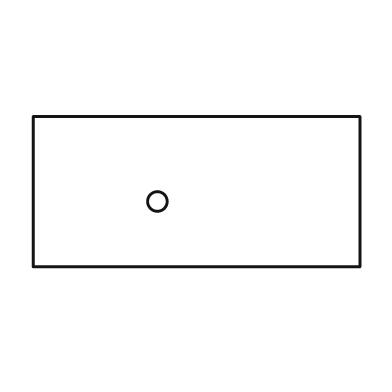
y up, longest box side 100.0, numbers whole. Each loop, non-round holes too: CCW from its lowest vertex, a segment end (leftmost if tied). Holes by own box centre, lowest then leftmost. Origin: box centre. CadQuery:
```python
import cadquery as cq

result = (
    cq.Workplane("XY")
    .moveTo(-50.0, -23.0)
    .lineTo(50.0, -23.0)
    .lineTo(50.0, 23.0)
    .lineTo(-50.0, 23.0)
    .close()
    .moveTo(-12.0, -3.0)
    .circle(3.0)
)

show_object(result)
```